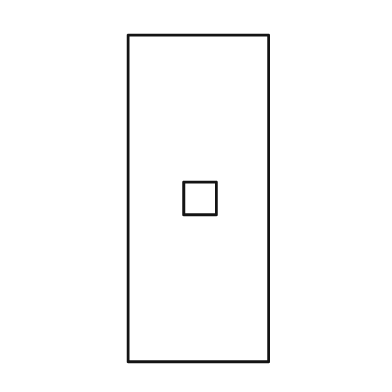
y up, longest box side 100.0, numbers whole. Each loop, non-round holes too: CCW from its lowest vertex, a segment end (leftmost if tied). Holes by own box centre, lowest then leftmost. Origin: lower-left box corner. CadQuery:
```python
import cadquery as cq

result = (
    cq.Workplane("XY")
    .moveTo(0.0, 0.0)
    .lineTo(43.0, 0.0)
    .lineTo(43.0, 100.0)
    .lineTo(0.0, 100.0)
    .close()
    .moveTo(17.0, 45.0)
    .lineTo(27.0, 45.0)
    .lineTo(27.0, 55.0)
    .lineTo(17.0, 55.0)
    .close()
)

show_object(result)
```